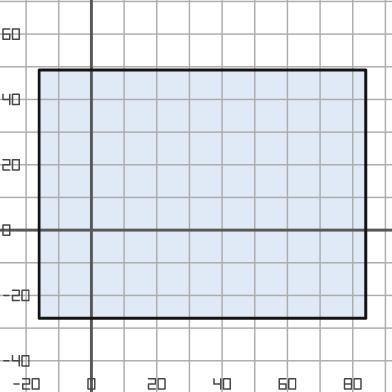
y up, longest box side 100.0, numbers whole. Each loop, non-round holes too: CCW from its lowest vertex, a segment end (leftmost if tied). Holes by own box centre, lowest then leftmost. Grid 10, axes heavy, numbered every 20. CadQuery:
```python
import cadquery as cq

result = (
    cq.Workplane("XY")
    .moveTo(-16.0, -27.0)
    .lineTo(84.0, -27.0)
    .lineTo(84.0, 49.0)
    .lineTo(-16.0, 49.0)
    .close()
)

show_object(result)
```